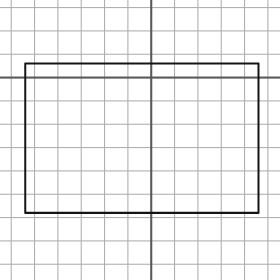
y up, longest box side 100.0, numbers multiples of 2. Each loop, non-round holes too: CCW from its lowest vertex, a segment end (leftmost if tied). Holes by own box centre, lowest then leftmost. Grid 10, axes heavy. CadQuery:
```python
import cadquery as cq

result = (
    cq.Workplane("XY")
    .moveTo(-54.0, -58.0)
    .lineTo(46.0, -58.0)
    .lineTo(46.0, 6.0)
    .lineTo(-54.0, 6.0)
    .close()
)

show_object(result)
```